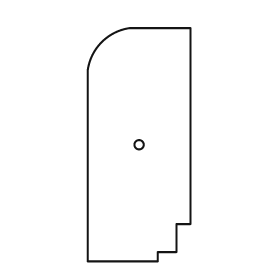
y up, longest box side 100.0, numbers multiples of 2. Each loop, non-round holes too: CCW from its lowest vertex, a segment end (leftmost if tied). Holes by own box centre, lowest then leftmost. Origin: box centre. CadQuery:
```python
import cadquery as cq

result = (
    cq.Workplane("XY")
    .moveTo(-22.0, -50.0)
    .lineTo(8.0, -50.0)
    .lineTo(8.0, -46.0)
    .lineTo(16.0, -46.0)
    .lineTo(16.0, -34.0)
    .lineTo(22.0, -34.0)
    .lineTo(22.0, 50.0)
    .lineTo(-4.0, 50.0)
    .threePointArc((-16.0, 44.0), (-22.0, 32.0))
    .close()
    .moveTo(0.0, 0.0)
    .circle(2.0)
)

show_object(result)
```